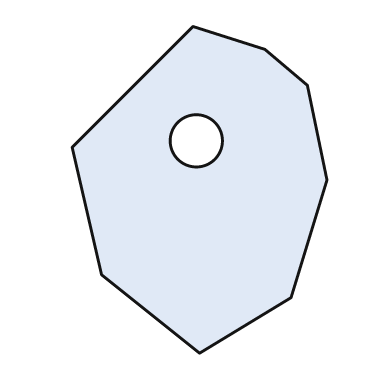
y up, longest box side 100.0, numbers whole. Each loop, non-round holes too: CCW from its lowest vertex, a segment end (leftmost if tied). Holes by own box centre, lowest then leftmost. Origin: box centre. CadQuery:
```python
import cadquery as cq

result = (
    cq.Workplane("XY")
    .moveTo(0.0, -50.0)
    .lineTo(28.0, -33.0)
    .lineTo(39.0, 3.0)
    .lineTo(33.0, 32.0)
    .lineTo(20.0, 43.0)
    .lineTo(-2.0, 50.0)
    .lineTo(-39.0, 13.0)
    .lineTo(-30.0, -26.0)
    .close()
    .moveTo(-1.0, 15.0)
    .circle(8.0)
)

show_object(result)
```